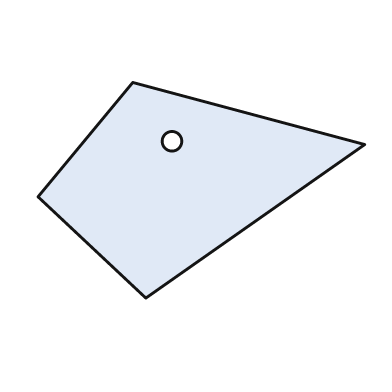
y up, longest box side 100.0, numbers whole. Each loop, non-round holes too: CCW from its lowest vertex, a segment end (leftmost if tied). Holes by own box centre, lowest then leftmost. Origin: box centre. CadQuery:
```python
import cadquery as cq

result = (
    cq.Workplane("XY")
    .moveTo(-17.0, -33.0)
    .lineTo(50.0, 14.0)
    .lineTo(-21.0, 33.0)
    .lineTo(-50.0, -2.0)
    .close()
    .moveTo(-9.0, 15.0)
    .circle(3.0)
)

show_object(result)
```